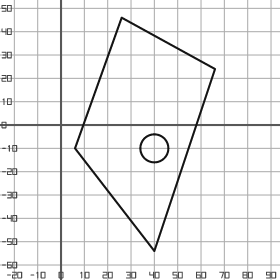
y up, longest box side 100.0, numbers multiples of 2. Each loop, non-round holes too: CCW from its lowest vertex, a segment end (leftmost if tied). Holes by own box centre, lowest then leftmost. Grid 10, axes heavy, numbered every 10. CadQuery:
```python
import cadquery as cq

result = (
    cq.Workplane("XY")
    .moveTo(40.0, -54.0)
    .lineTo(66.0, 24.0)
    .lineTo(26.0, 46.0)
    .lineTo(6.0, -10.0)
    .close()
    .moveTo(40.0, -10.0)
    .circle(6.0)
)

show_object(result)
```